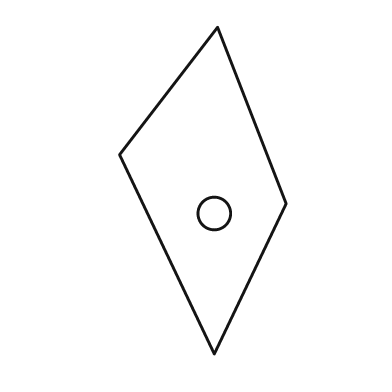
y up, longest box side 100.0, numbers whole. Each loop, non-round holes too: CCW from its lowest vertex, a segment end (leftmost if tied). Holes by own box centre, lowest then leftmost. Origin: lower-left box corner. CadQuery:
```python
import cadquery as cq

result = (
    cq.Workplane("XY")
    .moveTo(29.0, 0.0)
    .lineTo(51.0, 46.0)
    .lineTo(30.0, 100.0)
    .lineTo(0.0, 61.0)
    .close()
    .moveTo(29.0, 43.0)
    .circle(5.0)
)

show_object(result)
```